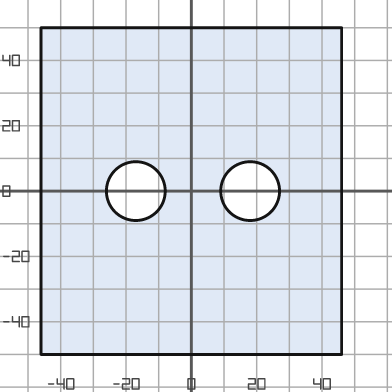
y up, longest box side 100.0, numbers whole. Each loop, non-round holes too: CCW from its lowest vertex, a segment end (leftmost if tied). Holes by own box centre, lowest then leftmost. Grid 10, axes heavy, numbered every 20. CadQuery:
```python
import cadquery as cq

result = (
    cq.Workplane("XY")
    .moveTo(-46.0, -50.0)
    .lineTo(46.0, -50.0)
    .lineTo(46.0, 50.0)
    .lineTo(-46.0, 50.0)
    .close()
    .moveTo(-17.0, 0.0)
    .circle(9.0)
    .moveTo(18.0, 0.0)
    .circle(9.0)
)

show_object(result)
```